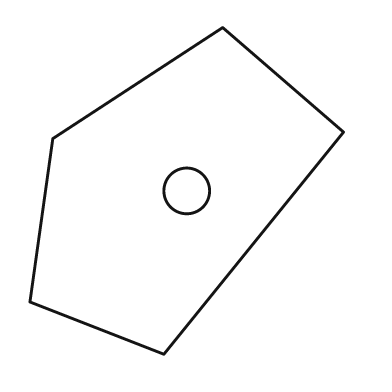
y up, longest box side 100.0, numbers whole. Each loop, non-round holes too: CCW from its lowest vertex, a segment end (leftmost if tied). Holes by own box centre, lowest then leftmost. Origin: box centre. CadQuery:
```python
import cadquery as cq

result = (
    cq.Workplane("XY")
    .moveTo(-7.0, -50.0)
    .lineTo(48.0, 18.0)
    .lineTo(11.0, 50.0)
    .lineTo(-41.0, 16.0)
    .lineTo(-48.0, -34.0)
    .close()
    .moveTo(0.0, 0.0)
    .circle(7.0)
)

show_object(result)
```